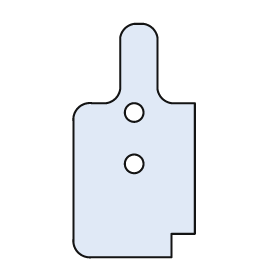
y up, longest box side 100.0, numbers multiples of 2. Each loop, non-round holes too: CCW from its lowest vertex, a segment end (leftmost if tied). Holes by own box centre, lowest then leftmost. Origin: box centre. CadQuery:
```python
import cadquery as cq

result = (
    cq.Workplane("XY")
    .moveTo(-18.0, -50.0)
    .lineTo(16.0, -50.0)
    .lineTo(16.0, -40.0)
    .lineTo(26.0, -40.0)
    .lineTo(26.0, 16.0)
    .lineTo(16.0, 16.0)
    .threePointArc((12.0, 18.0), (10.0, 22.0))
    .lineTo(10.0, 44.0)
    .threePointArc((8.0, 48.0), (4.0, 50.0))
    .lineTo(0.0, 50.0)
    .threePointArc((-4.0, 48.0), (-6.0, 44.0))
    .lineTo(-6.0, 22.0)
    .threePointArc((-8.0, 18.0), (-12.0, 16.0))
    .lineTo(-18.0, 16.0)
    .threePointArc((-24.0, 14.0), (-26.0, 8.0))
    .lineTo(-26.0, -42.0)
    .threePointArc((-24.0, -48.0), (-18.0, -50.0))
    .close()
    .moveTo(0.0, -10.0)
    .circle(4.0)
    .moveTo(0.0, 12.0)
    .circle(4.0)
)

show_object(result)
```